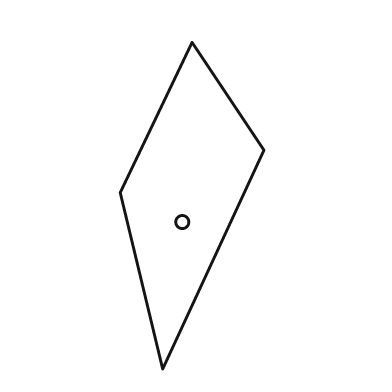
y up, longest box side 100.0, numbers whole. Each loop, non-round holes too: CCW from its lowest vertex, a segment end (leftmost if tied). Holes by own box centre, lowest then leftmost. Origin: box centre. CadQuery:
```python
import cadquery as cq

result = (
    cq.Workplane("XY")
    .moveTo(-9.0, -50.0)
    .lineTo(22.0, 17.0)
    .lineTo(0.0, 50.0)
    .lineTo(-22.0, 4.0)
    .close()
    .moveTo(-3.0, -5.0)
    .circle(2.0)
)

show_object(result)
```